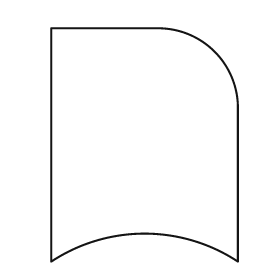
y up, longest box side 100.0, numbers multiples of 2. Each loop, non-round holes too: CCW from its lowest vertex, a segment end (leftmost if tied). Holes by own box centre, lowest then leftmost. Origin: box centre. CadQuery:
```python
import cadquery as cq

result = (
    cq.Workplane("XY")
    .moveTo(-40.0, -50.0)
    .threePointArc((0.0, -38.0), (40.0, -50.0))
    .lineTo(40.0, 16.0)
    .threePointArc((30.0, 40.0), (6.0, 50.0))
    .lineTo(-40.0, 50.0)
    .close()
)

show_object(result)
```